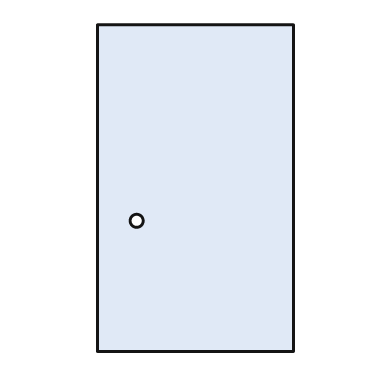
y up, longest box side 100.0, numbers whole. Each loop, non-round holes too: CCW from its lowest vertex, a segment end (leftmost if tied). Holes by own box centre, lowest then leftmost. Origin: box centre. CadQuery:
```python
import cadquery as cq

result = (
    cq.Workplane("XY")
    .moveTo(-30.0, -50.0)
    .lineTo(30.0, -50.0)
    .lineTo(30.0, 50.0)
    .lineTo(-30.0, 50.0)
    .close()
    .moveTo(-18.0, -10.0)
    .circle(2.0)
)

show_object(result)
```